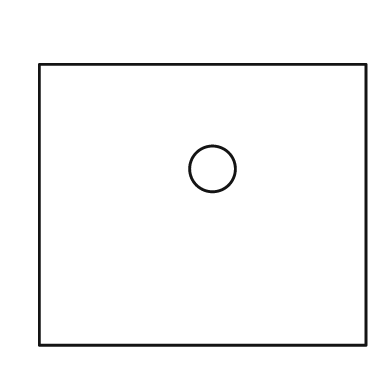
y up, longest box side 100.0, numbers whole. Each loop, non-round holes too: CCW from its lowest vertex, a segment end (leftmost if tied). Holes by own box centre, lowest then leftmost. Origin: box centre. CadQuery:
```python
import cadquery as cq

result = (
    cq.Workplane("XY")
    .moveTo(-50.0, -43.0)
    .lineTo(50.0, -43.0)
    .lineTo(50.0, 43.0)
    .lineTo(-50.0, 43.0)
    .close()
    .moveTo(3.0, 11.0)
    .circle(7.0)
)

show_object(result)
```